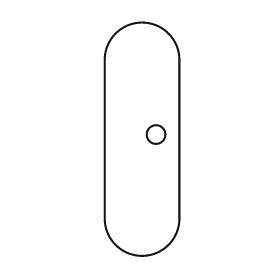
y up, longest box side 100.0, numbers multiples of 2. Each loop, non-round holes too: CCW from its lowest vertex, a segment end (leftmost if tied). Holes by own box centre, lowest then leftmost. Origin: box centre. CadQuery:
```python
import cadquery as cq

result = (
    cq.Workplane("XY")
    .moveTo(-16.0, -34.0)
    .threePointArc((0.0, -50.0), (16.0, -34.0))
    .lineTo(16.0, 34.0)
    .threePointArc((0.0, 50.0), (-16.0, 34.0))
    .close()
    .moveTo(6.0, 2.0)
    .circle(4.0)
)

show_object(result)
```